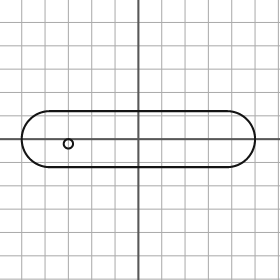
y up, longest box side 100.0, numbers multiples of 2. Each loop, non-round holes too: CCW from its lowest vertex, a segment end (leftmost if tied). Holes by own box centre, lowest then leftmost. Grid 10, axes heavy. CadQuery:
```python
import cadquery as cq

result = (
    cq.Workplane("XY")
    .moveTo(-38.0, -12.0)
    .lineTo(38.0, -12.0)
    .threePointArc((50.0, 0.0), (38.0, 12.0))
    .lineTo(-38.0, 12.0)
    .threePointArc((-50.0, 0.0), (-38.0, -12.0))
    .close()
    .moveTo(-30.0, -2.0)
    .circle(2.0)
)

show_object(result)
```